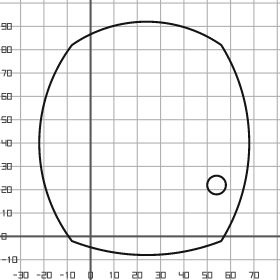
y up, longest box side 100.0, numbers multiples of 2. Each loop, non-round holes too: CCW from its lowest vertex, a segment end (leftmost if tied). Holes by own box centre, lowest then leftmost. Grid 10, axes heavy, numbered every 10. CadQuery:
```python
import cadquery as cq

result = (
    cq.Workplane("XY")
    .moveTo(-8.0, -2.0)
    .threePointArc((24.0, -8.0), (56.0, -2.0))
    .threePointArc((68.0, 40.0), (56.0, 82.0))
    .threePointArc((24.0, 92.0), (-8.0, 82.0))
    .threePointArc((-22.0, 40.0), (-8.0, -2.0))
    .close()
    .moveTo(54.0, 22.0)
    .circle(4.0)
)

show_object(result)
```